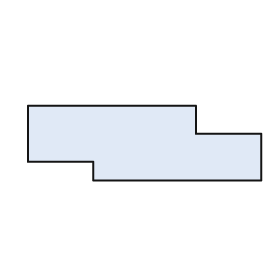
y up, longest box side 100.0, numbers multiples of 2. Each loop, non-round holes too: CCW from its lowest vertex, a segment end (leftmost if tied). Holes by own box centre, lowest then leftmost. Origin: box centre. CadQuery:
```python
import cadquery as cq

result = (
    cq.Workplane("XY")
    .moveTo(-22.0, -16.0)
    .lineTo(50.0, -16.0)
    .lineTo(50.0, 4.0)
    .lineTo(22.0, 4.0)
    .lineTo(22.0, 16.0)
    .lineTo(-50.0, 16.0)
    .lineTo(-50.0, -8.0)
    .lineTo(-22.0, -8.0)
    .close()
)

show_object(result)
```